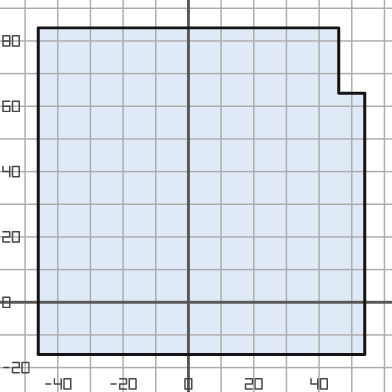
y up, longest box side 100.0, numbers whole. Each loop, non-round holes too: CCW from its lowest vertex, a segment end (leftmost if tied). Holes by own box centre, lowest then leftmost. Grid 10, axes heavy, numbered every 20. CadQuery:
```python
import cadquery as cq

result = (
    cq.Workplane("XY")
    .moveTo(-46.0, -16.0)
    .lineTo(54.0, -16.0)
    .lineTo(54.0, 64.0)
    .lineTo(46.0, 64.0)
    .lineTo(46.0, 84.0)
    .lineTo(-46.0, 84.0)
    .close()
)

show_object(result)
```